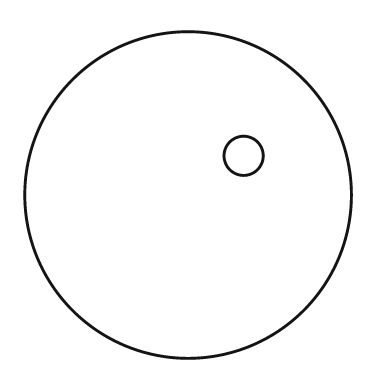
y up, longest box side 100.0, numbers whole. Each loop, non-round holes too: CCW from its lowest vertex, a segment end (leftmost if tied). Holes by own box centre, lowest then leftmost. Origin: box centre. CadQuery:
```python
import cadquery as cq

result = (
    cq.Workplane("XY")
    .moveTo(0.0, 0.0)
    .circle(50.0)
    .moveTo(17.0, 12.0)
    .circle(6.0)
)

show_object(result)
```